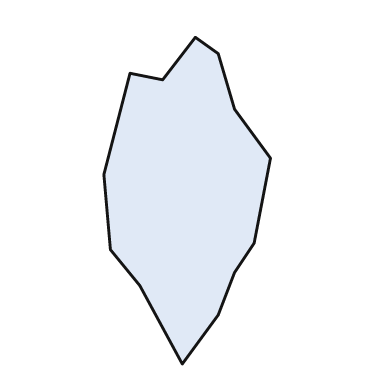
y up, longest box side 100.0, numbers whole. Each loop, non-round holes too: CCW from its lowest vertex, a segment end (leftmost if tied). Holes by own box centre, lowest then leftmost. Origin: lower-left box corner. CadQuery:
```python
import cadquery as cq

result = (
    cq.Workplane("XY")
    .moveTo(24.0, 0.0)
    .lineTo(35.0, 15.0)
    .lineTo(40.0, 28.0)
    .lineTo(46.0, 37.0)
    .lineTo(51.0, 63.0)
    .lineTo(40.0, 78.0)
    .lineTo(35.0, 95.0)
    .lineTo(28.0, 100.0)
    .lineTo(18.0, 87.0)
    .lineTo(8.0, 89.0)
    .lineTo(0.0, 58.0)
    .lineTo(2.0, 35.0)
    .lineTo(11.0, 24.0)
    .close()
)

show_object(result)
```